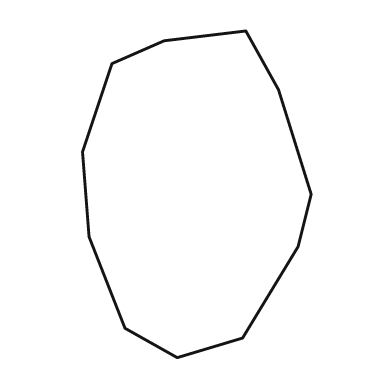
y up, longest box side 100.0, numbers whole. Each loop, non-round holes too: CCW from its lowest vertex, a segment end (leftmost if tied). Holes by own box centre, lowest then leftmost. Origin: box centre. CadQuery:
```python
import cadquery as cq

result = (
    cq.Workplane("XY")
    .moveTo(-6.0, -50.0)
    .lineTo(14.0, -44.0)
    .lineTo(31.0, -16.0)
    .lineTo(35.0, 0.0)
    .lineTo(25.0, 32.0)
    .lineTo(15.0, 50.0)
    .lineTo(-10.0, 47.0)
    .lineTo(-26.0, 40.0)
    .lineTo(-35.0, 13.0)
    .lineTo(-33.0, -13.0)
    .lineTo(-22.0, -41.0)
    .close()
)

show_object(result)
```